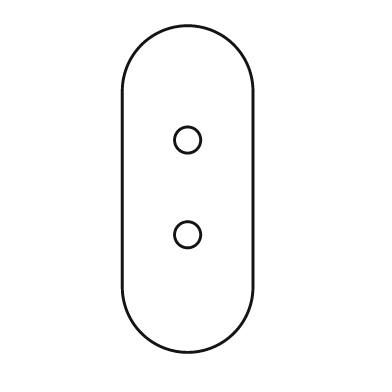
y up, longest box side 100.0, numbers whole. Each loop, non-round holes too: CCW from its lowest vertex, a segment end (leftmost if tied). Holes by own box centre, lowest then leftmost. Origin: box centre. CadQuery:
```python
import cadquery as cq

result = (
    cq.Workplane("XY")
    .moveTo(-20.0, -30.0)
    .threePointArc((0.0, -50.0), (20.0, -30.0))
    .lineTo(20.0, 30.0)
    .threePointArc((0.0, 50.0), (-20.0, 30.0))
    .close()
    .moveTo(0.0, -14.0)
    .circle(4.0)
    .moveTo(0.0, 15.0)
    .circle(4.0)
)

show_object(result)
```